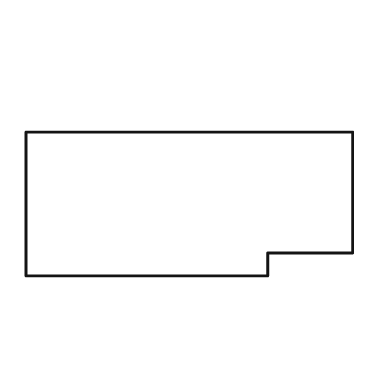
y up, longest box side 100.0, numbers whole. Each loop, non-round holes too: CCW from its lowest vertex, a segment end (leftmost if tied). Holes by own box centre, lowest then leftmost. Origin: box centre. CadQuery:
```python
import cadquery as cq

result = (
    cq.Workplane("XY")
    .moveTo(-50.0, -22.0)
    .lineTo(24.0, -22.0)
    .lineTo(24.0, -15.0)
    .lineTo(50.0, -15.0)
    .lineTo(50.0, 22.0)
    .lineTo(-50.0, 22.0)
    .close()
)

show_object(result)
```